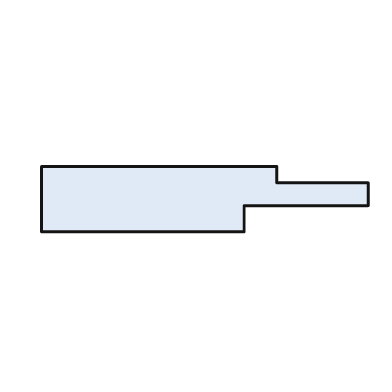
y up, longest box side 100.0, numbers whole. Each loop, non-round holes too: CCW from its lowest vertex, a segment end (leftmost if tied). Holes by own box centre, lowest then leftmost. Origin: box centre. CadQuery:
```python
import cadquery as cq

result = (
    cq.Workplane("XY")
    .moveTo(-50.0, -10.0)
    .lineTo(12.0, -10.0)
    .lineTo(12.0, -2.0)
    .lineTo(50.0, -2.0)
    .lineTo(50.0, 5.0)
    .lineTo(22.0, 5.0)
    .lineTo(22.0, 10.0)
    .lineTo(-50.0, 10.0)
    .close()
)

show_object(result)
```